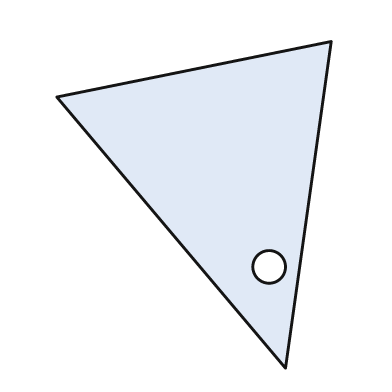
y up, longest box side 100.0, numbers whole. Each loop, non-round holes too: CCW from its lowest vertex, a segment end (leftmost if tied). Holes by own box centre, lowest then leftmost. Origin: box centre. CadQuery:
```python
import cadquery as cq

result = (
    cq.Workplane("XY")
    .moveTo(28.0, -50.0)
    .lineTo(42.0, 50.0)
    .lineTo(-42.0, 33.0)
    .close()
    .moveTo(23.0, -19.0)
    .circle(5.0)
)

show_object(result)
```